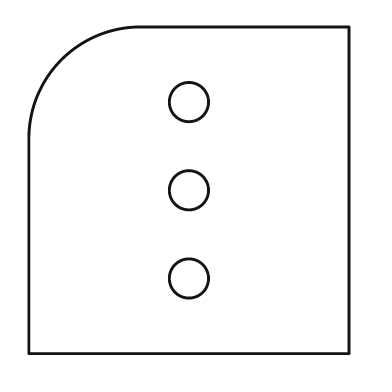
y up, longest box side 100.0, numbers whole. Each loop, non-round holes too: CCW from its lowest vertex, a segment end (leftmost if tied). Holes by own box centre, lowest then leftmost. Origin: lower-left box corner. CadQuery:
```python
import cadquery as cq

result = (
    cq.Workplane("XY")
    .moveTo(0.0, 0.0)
    .lineTo(98.0, 0.0)
    .lineTo(98.0, 100.0)
    .lineTo(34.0, 100.0)
    .threePointArc((10.0, 90.0), (0.0, 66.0))
    .close()
    .moveTo(49.0, 23.0)
    .circle(6.0)
    .moveTo(49.0, 50.0)
    .circle(6.0)
    .moveTo(49.0, 77.0)
    .circle(6.0)
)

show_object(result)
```